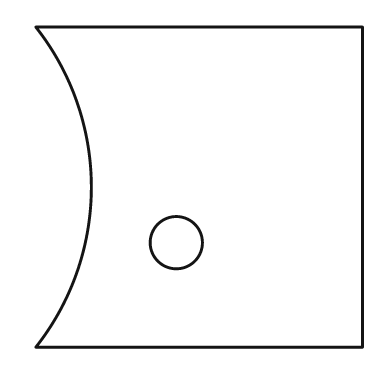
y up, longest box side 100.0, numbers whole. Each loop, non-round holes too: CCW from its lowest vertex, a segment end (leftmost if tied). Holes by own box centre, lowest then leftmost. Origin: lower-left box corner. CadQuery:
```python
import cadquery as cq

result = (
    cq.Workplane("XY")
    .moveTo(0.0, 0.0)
    .lineTo(100.0, 0.0)
    .lineTo(100.0, 98.0)
    .lineTo(0.0, 98.0)
    .threePointArc((17.0, 49.0), (0.0, 0.0))
    .close()
    .moveTo(43.0, 32.0)
    .circle(8.0)
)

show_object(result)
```